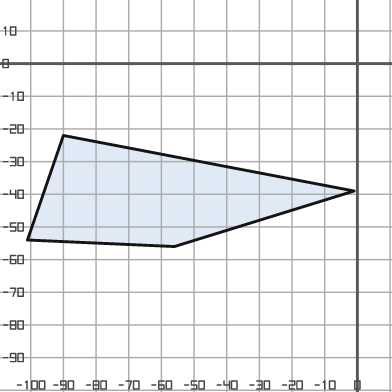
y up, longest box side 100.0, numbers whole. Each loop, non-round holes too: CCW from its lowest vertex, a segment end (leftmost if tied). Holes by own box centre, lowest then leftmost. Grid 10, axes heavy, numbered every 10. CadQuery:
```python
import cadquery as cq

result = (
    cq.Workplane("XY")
    .moveTo(-56.0, -56.0)
    .lineTo(-1.0, -39.0)
    .lineTo(-90.0, -22.0)
    .lineTo(-101.0, -54.0)
    .close()
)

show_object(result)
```